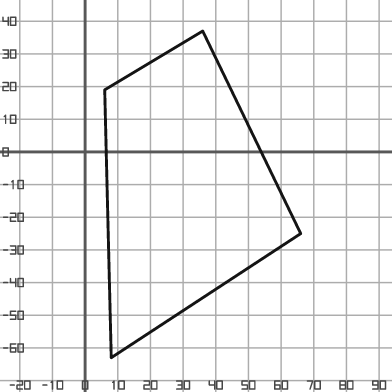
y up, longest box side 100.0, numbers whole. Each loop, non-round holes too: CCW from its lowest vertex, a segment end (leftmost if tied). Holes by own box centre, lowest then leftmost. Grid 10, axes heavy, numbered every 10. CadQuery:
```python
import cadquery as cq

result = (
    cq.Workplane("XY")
    .moveTo(8.0, -63.0)
    .lineTo(66.0, -25.0)
    .lineTo(36.0, 37.0)
    .lineTo(6.0, 19.0)
    .close()
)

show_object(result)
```